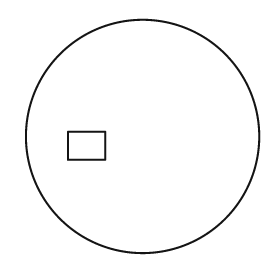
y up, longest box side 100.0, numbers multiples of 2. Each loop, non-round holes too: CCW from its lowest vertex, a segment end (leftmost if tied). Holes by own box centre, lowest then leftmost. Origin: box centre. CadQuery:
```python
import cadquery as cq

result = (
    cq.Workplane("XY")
    .moveTo(0.0, 0.0)
    .circle(50.0)
    .moveTo(-32.0, -10.0)
    .lineTo(-16.0, -10.0)
    .lineTo(-16.0, 2.0)
    .lineTo(-32.0, 2.0)
    .close()
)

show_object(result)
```